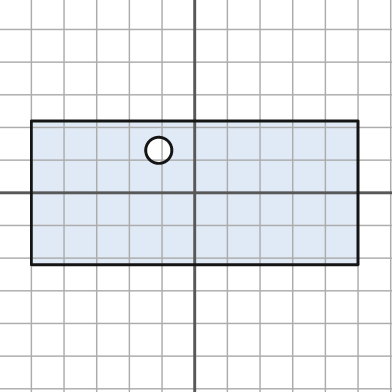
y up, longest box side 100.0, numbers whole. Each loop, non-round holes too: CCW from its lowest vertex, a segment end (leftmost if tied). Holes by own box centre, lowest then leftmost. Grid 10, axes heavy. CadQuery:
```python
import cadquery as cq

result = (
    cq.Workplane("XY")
    .moveTo(-50.0, -22.0)
    .lineTo(50.0, -22.0)
    .lineTo(50.0, 22.0)
    .lineTo(-50.0, 22.0)
    .close()
    .moveTo(-11.0, 13.0)
    .circle(4.0)
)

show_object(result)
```